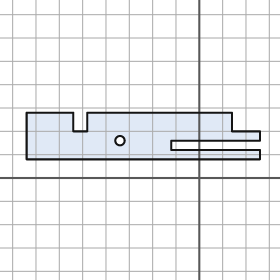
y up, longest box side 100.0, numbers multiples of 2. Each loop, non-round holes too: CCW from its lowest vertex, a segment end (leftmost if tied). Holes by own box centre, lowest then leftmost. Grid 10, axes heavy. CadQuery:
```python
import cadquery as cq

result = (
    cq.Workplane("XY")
    .moveTo(-74.0, 8.0)
    .lineTo(26.0, 8.0)
    .lineTo(26.0, 12.0)
    .lineTo(-12.0, 12.0)
    .lineTo(-12.0, 16.0)
    .lineTo(26.0, 16.0)
    .lineTo(26.0, 20.0)
    .lineTo(14.0, 20.0)
    .lineTo(14.0, 28.0)
    .lineTo(-48.0, 28.0)
    .lineTo(-48.0, 20.0)
    .lineTo(-54.0, 20.0)
    .lineTo(-54.0, 28.0)
    .lineTo(-74.0, 28.0)
    .close()
    .moveTo(-34.0, 16.0)
    .circle(2.0)
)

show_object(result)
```